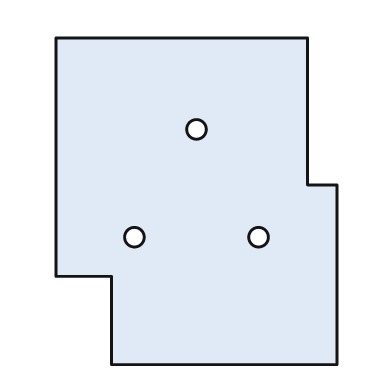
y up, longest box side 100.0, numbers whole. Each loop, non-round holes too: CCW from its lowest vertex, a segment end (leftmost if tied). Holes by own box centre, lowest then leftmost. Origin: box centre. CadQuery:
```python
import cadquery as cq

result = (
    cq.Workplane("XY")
    .moveTo(-26.0, -50.0)
    .lineTo(43.0, -50.0)
    .lineTo(43.0, 5.0)
    .lineTo(34.0, 5.0)
    .lineTo(34.0, 50.0)
    .lineTo(-43.0, 50.0)
    .lineTo(-43.0, -23.0)
    .lineTo(-26.0, -23.0)
    .close()
    .moveTo(-19.0, -11.0)
    .circle(3.0)
    .moveTo(19.0, -11.0)
    .circle(3.0)
    .moveTo(0.0, 22.0)
    .circle(3.0)
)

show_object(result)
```